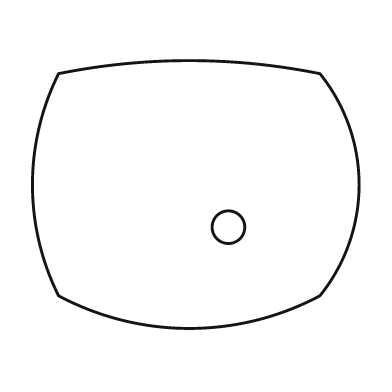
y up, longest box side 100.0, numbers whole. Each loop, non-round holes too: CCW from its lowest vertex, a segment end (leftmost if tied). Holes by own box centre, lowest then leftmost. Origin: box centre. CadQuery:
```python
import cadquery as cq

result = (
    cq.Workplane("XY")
    .moveTo(-42.0, -31.0)
    .threePointArc((-2.0, -41.0), (38.0, -31.0))
    .threePointArc((50.0, 3.0), (38.0, 37.0))
    .threePointArc((-2.0, 41.0), (-42.0, 37.0))
    .threePointArc((-50.0, 3.0), (-42.0, -31.0))
    .close()
    .moveTo(10.0, -10.0)
    .circle(5.0)
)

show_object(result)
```